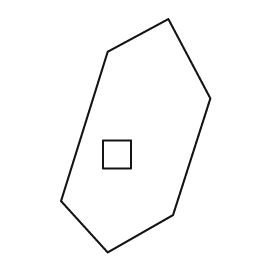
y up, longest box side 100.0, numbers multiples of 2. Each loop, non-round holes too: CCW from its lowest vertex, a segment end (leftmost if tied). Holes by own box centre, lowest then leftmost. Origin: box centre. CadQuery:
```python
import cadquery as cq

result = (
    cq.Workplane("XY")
    .moveTo(-12.0, -50.0)
    .lineTo(16.0, -34.0)
    .lineTo(32.0, 16.0)
    .lineTo(14.0, 50.0)
    .lineTo(-12.0, 36.0)
    .lineTo(-32.0, -28.0)
    .close()
    .moveTo(-14.0, -14.0)
    .lineTo(-2.0, -14.0)
    .lineTo(-2.0, -2.0)
    .lineTo(-14.0, -2.0)
    .close()
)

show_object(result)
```